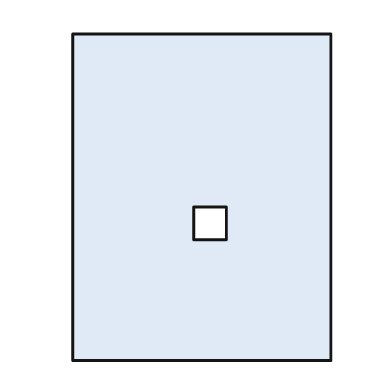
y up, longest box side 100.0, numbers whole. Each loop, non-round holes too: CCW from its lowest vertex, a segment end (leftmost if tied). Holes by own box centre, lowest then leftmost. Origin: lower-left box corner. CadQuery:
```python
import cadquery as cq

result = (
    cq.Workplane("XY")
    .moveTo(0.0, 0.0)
    .lineTo(79.0, 0.0)
    .lineTo(79.0, 100.0)
    .lineTo(0.0, 100.0)
    .close()
    .moveTo(37.0, 37.0)
    .lineTo(47.0, 37.0)
    .lineTo(47.0, 47.0)
    .lineTo(37.0, 47.0)
    .close()
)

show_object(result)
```